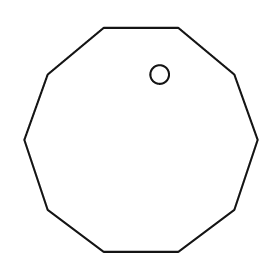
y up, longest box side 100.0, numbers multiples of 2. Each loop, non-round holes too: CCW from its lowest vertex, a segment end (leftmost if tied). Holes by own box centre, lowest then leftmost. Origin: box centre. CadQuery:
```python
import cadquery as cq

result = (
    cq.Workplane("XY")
    .moveTo(-16.0, -48.0)
    .lineTo(16.0, -48.0)
    .lineTo(40.0, -30.0)
    .lineTo(50.0, 0.0)
    .lineTo(40.0, 28.0)
    .lineTo(16.0, 48.0)
    .lineTo(-16.0, 48.0)
    .lineTo(-40.0, 28.0)
    .lineTo(-50.0, 0.0)
    .lineTo(-40.0, -30.0)
    .close()
    .moveTo(8.0, 28.0)
    .circle(4.0)
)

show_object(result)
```